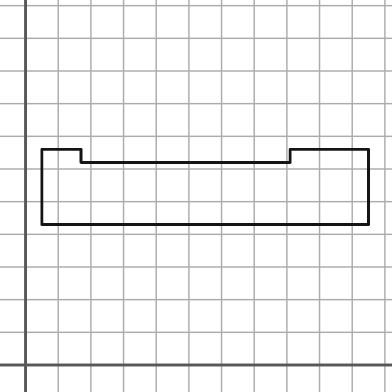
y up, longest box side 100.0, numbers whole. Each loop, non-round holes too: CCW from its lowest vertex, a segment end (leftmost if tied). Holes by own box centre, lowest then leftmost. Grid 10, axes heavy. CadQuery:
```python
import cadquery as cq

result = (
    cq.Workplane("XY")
    .moveTo(5.0, 43.0)
    .lineTo(105.0, 43.0)
    .lineTo(105.0, 66.0)
    .lineTo(81.0, 66.0)
    .lineTo(81.0, 62.0)
    .lineTo(17.0, 62.0)
    .lineTo(17.0, 66.0)
    .lineTo(5.0, 66.0)
    .close()
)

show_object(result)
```